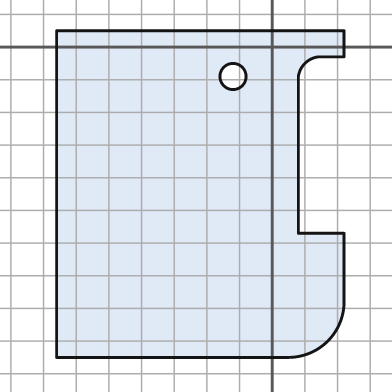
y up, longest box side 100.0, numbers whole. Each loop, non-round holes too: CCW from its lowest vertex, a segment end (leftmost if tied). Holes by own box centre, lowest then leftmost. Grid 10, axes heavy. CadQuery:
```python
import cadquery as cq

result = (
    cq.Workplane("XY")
    .moveTo(-66.0, -95.0)
    .lineTo(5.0, -95.0)
    .threePointArc((17.0, -90.0), (22.0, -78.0))
    .lineTo(22.0, -57.0)
    .lineTo(8.0, -57.0)
    .lineTo(8.0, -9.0)
    .threePointArc((10.0, -5.0), (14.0, -3.0))
    .lineTo(22.0, -3.0)
    .lineTo(22.0, 5.0)
    .lineTo(-66.0, 5.0)
    .close()
    .moveTo(-12.0, -9.0)
    .circle(4.0)
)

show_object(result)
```